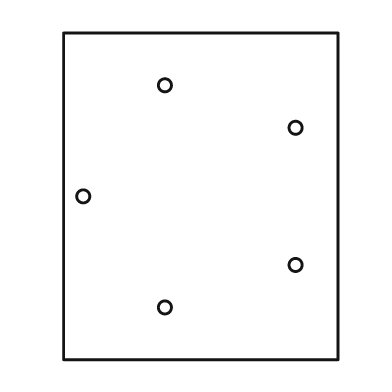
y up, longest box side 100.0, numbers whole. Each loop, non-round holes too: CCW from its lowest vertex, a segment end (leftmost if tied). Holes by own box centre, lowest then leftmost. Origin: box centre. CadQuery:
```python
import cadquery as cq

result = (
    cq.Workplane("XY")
    .moveTo(-42.0, -50.0)
    .lineTo(42.0, -50.0)
    .lineTo(42.0, 50.0)
    .lineTo(-42.0, 50.0)
    .close()
    .moveTo(-11.0, -34.0)
    .circle(2.0)
    .moveTo(29.0, -21.0)
    .circle(2.0)
    .moveTo(-36.0, 0.0)
    .circle(2.0)
    .moveTo(29.0, 21.0)
    .circle(2.0)
    .moveTo(-11.0, 34.0)
    .circle(2.0)
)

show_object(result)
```